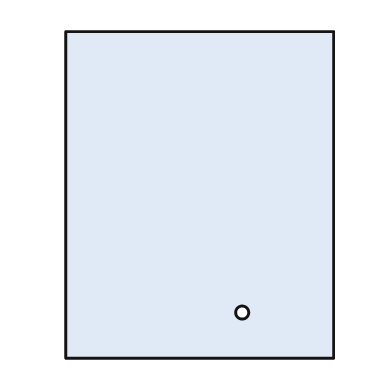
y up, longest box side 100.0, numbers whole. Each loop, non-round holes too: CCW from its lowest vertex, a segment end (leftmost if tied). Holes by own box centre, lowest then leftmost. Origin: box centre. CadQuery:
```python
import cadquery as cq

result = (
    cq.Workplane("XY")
    .moveTo(-41.0, -50.0)
    .lineTo(41.0, -50.0)
    .lineTo(41.0, 50.0)
    .lineTo(-41.0, 50.0)
    .close()
    .moveTo(13.0, -36.0)
    .circle(2.0)
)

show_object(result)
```